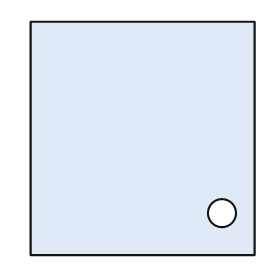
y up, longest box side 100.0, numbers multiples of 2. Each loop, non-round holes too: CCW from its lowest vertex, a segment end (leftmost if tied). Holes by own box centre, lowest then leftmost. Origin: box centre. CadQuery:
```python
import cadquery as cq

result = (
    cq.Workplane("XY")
    .moveTo(-48.0, -50.0)
    .lineTo(48.0, -50.0)
    .lineTo(48.0, 50.0)
    .lineTo(-48.0, 50.0)
    .close()
    .moveTo(34.0, -32.0)
    .circle(6.0)
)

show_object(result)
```